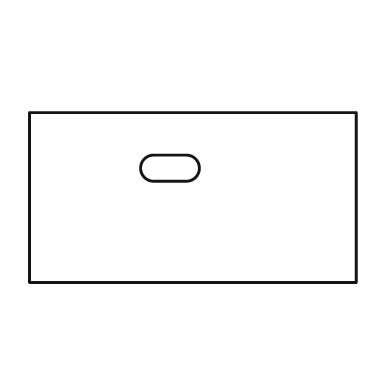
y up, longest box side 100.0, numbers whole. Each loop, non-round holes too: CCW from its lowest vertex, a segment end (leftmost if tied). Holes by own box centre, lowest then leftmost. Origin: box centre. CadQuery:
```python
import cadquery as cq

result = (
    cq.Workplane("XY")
    .moveTo(-50.0, -26.0)
    .lineTo(50.0, -26.0)
    .lineTo(50.0, 26.0)
    .lineTo(-50.0, 26.0)
    .close()
    .moveTo(-12.0, 5.0)
    .lineTo(-2.0, 5.0)
    .threePointArc((2.0, 9.0), (-2.0, 13.0))
    .lineTo(-12.0, 13.0)
    .threePointArc((-16.0, 9.0), (-12.0, 5.0))
    .close()
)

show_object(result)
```